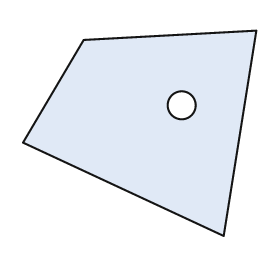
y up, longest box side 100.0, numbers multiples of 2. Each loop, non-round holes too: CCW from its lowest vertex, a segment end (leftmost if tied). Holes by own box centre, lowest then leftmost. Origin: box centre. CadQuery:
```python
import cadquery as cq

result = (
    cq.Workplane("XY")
    .moveTo(36.0, -44.0)
    .lineTo(50.0, 44.0)
    .lineTo(-24.0, 40.0)
    .lineTo(-50.0, -4.0)
    .close()
    .moveTo(18.0, 12.0)
    .circle(6.0)
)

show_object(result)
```